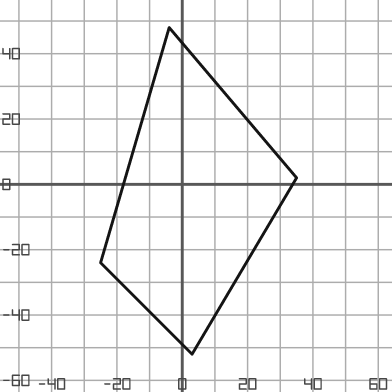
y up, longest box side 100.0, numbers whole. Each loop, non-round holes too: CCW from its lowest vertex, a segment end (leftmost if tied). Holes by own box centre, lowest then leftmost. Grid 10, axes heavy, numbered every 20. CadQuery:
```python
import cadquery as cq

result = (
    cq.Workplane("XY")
    .moveTo(3.0, -52.0)
    .lineTo(35.0, 2.0)
    .lineTo(-4.0, 48.0)
    .lineTo(-25.0, -24.0)
    .close()
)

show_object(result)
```